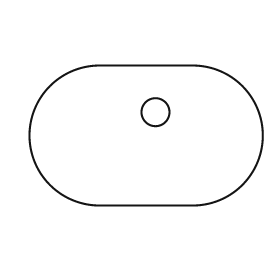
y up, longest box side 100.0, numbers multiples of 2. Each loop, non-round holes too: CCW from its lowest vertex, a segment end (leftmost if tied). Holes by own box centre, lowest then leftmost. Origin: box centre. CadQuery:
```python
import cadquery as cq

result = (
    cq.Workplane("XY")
    .moveTo(-20.0, -30.0)
    .lineTo(20.0, -30.0)
    .threePointArc((50.0, 0.0), (20.0, 30.0))
    .lineTo(-20.0, 30.0)
    .threePointArc((-50.0, 0.0), (-20.0, -30.0))
    .close()
    .moveTo(4.0, 10.0)
    .circle(6.0)
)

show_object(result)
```